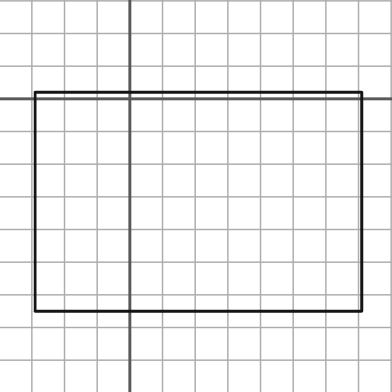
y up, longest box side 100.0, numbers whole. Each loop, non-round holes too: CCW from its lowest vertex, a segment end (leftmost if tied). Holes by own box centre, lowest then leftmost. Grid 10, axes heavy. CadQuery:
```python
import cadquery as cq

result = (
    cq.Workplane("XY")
    .moveTo(-29.0, -65.0)
    .lineTo(71.0, -65.0)
    .lineTo(71.0, 2.0)
    .lineTo(-29.0, 2.0)
    .close()
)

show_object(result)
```